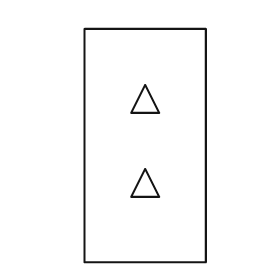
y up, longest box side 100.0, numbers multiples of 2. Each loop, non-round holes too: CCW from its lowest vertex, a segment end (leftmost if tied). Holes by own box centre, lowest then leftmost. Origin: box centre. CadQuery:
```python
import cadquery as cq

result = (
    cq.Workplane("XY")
    .moveTo(-26.0, -50.0)
    .lineTo(26.0, -50.0)
    .lineTo(26.0, 50.0)
    .lineTo(-26.0, 50.0)
    .close()
    .moveTo(-6.0, -22.0)
    .lineTo(6.0, -22.0)
    .lineTo(0.0, -10.0)
    .close()
    .moveTo(-6.0, 14.0)
    .lineTo(6.0, 14.0)
    .lineTo(0.0, 26.0)
    .close()
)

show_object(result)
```